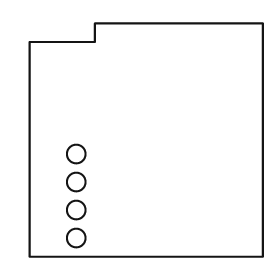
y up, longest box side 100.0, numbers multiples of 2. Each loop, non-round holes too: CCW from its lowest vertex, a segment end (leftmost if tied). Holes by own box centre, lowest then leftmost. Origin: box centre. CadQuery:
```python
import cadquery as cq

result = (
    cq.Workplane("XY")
    .moveTo(-50.0, -50.0)
    .lineTo(50.0, -50.0)
    .lineTo(50.0, 50.0)
    .lineTo(-22.0, 50.0)
    .lineTo(-22.0, 42.0)
    .lineTo(-50.0, 42.0)
    .close()
    .moveTo(-30.0, -42.0)
    .circle(4.0)
    .moveTo(-30.0, -30.0)
    .circle(4.0)
    .moveTo(-30.0, -18.0)
    .circle(4.0)
    .moveTo(-30.0, -6.0)
    .circle(4.0)
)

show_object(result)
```